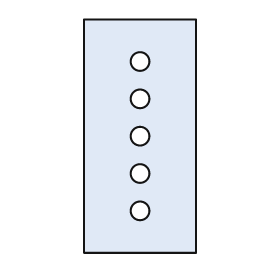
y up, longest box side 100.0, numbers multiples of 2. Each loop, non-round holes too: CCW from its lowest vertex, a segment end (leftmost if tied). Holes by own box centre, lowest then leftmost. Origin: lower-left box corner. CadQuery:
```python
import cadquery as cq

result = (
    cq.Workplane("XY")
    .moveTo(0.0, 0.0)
    .lineTo(48.0, 0.0)
    .lineTo(48.0, 100.0)
    .lineTo(0.0, 100.0)
    .close()
    .moveTo(24.0, 18.0)
    .circle(4.0)
    .moveTo(24.0, 34.0)
    .circle(4.0)
    .moveTo(24.0, 50.0)
    .circle(4.0)
    .moveTo(24.0, 66.0)
    .circle(4.0)
    .moveTo(24.0, 82.0)
    .circle(4.0)
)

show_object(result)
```